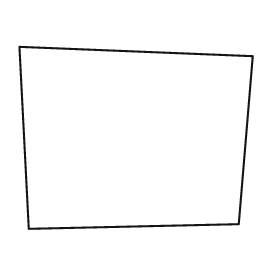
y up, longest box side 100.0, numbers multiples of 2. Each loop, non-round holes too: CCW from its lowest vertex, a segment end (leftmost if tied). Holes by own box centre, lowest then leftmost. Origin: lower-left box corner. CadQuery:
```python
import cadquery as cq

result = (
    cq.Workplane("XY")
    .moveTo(4.0, 0.0)
    .lineTo(94.0, 2.0)
    .lineTo(100.0, 74.0)
    .lineTo(0.0, 78.0)
    .close()
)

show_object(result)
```